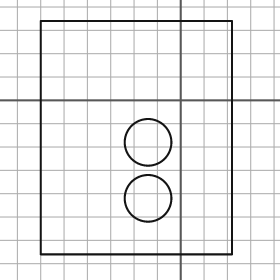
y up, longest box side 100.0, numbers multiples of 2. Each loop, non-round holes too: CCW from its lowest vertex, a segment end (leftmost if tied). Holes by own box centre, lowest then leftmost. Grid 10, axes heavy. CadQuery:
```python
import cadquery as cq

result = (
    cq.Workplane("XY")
    .moveTo(-60.0, -66.0)
    .lineTo(22.0, -66.0)
    .lineTo(22.0, 34.0)
    .lineTo(-60.0, 34.0)
    .close()
    .moveTo(-14.0, -42.0)
    .circle(10.0)
    .moveTo(-14.0, -18.0)
    .circle(10.0)
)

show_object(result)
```